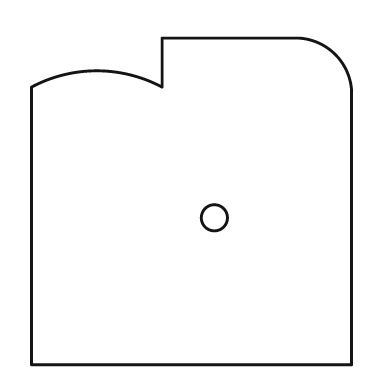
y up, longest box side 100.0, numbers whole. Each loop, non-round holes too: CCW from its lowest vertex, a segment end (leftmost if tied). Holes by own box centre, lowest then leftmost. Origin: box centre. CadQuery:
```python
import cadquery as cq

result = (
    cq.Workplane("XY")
    .moveTo(-49.0, -50.0)
    .lineTo(49.0, -50.0)
    .lineTo(49.0, 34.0)
    .threePointArc((44.0, 45.0), (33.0, 50.0))
    .lineTo(-9.0, 50.0)
    .lineTo(-9.0, 35.0)
    .threePointArc((-29.0, 40.0), (-49.0, 35.0))
    .close()
    .moveTo(7.0, -5.0)
    .circle(4.0)
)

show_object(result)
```